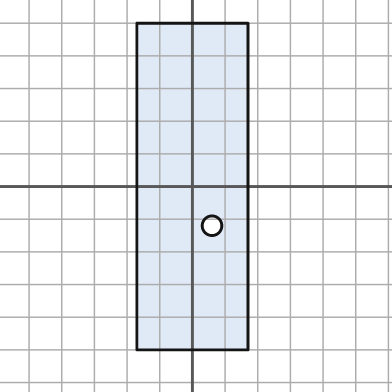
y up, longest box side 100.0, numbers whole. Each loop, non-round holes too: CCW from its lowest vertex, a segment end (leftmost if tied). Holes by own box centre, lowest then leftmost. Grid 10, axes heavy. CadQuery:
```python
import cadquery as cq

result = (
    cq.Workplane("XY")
    .moveTo(-17.0, -50.0)
    .lineTo(17.0, -50.0)
    .lineTo(17.0, 50.0)
    .lineTo(-17.0, 50.0)
    .close()
    .moveTo(6.0, -12.0)
    .circle(3.0)
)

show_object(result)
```